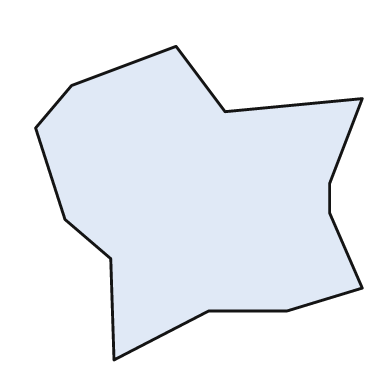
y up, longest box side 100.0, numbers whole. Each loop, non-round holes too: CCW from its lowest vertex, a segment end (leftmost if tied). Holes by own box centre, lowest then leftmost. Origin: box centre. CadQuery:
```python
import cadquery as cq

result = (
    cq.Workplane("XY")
    .moveTo(-26.0, -48.0)
    .lineTo(3.0, -33.0)
    .lineTo(27.0, -33.0)
    .lineTo(50.0, -26.0)
    .lineTo(40.0, -3.0)
    .lineTo(40.0, 6.0)
    .lineTo(50.0, 32.0)
    .lineTo(8.0, 28.0)
    .lineTo(-7.0, 48.0)
    .lineTo(-39.0, 36.0)
    .lineTo(-50.0, 23.0)
    .lineTo(-41.0, -5.0)
    .lineTo(-27.0, -17.0)
    .close()
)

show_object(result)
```